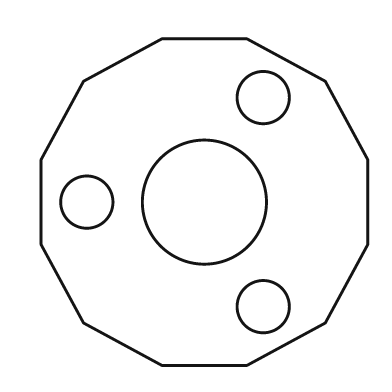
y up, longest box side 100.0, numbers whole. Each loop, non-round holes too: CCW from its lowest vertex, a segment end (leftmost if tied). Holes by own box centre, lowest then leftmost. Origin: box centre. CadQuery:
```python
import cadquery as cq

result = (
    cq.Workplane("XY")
    .moveTo(-13.0, -50.0)
    .lineTo(13.0, -50.0)
    .lineTo(37.0, -37.0)
    .lineTo(50.0, -13.0)
    .lineTo(50.0, 13.0)
    .lineTo(37.0, 37.0)
    .lineTo(13.0, 50.0)
    .lineTo(-13.0, 50.0)
    .lineTo(-37.0, 37.0)
    .lineTo(-50.0, 13.0)
    .lineTo(-50.0, -13.0)
    .lineTo(-37.0, -37.0)
    .close()
    .moveTo(18.0, -32.0)
    .circle(8.0)
    .moveTo(-36.0, 0.0)
    .circle(8.0)
    .moveTo(0.0, 0.0)
    .circle(19.0)
    .moveTo(18.0, 32.0)
    .circle(8.0)
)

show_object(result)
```